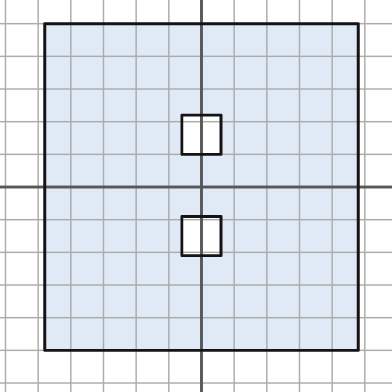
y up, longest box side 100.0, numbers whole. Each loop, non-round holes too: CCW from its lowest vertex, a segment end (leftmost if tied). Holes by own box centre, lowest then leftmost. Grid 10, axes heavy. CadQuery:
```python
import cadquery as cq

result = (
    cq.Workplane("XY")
    .moveTo(-48.0, -50.0)
    .lineTo(48.0, -50.0)
    .lineTo(48.0, 50.0)
    .lineTo(-48.0, 50.0)
    .close()
    .moveTo(-6.0, -21.0)
    .lineTo(6.0, -21.0)
    .lineTo(6.0, -9.0)
    .lineTo(-6.0, -9.0)
    .close()
    .moveTo(-6.0, 10.0)
    .lineTo(6.0, 10.0)
    .lineTo(6.0, 22.0)
    .lineTo(-6.0, 22.0)
    .close()
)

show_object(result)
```